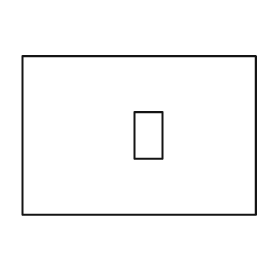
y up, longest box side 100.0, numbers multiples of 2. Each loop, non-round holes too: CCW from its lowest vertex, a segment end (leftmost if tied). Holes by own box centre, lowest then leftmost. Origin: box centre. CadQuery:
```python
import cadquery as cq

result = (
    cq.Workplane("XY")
    .moveTo(-50.0, -34.0)
    .lineTo(50.0, -34.0)
    .lineTo(50.0, 34.0)
    .lineTo(-50.0, 34.0)
    .close()
    .moveTo(-2.0, -10.0)
    .lineTo(10.0, -10.0)
    .lineTo(10.0, 10.0)
    .lineTo(-2.0, 10.0)
    .close()
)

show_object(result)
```